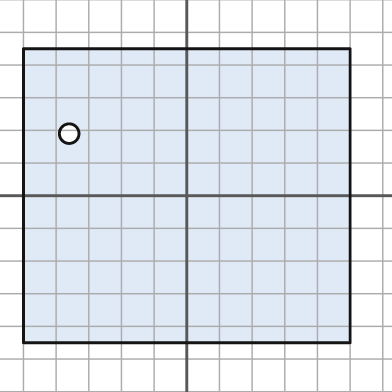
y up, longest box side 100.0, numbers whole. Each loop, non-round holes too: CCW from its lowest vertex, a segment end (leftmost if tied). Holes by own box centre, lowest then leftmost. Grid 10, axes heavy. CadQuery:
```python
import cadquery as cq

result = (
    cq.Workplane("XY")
    .moveTo(-50.0, -45.0)
    .lineTo(50.0, -45.0)
    .lineTo(50.0, 45.0)
    .lineTo(-50.0, 45.0)
    .close()
    .moveTo(-36.0, 19.0)
    .circle(3.0)
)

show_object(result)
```